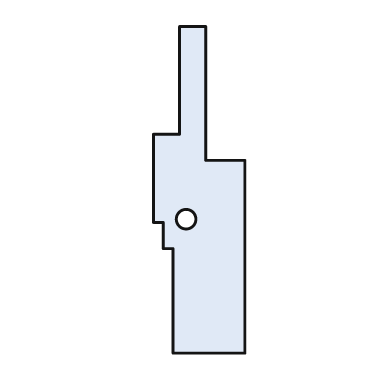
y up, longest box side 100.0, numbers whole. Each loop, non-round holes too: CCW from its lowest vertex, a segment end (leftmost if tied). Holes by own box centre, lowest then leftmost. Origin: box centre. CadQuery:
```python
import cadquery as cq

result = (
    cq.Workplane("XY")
    .moveTo(-8.0, -50.0)
    .lineTo(14.0, -50.0)
    .lineTo(14.0, 9.0)
    .lineTo(2.0, 9.0)
    .lineTo(2.0, 50.0)
    .lineTo(-6.0, 50.0)
    .lineTo(-6.0, 17.0)
    .lineTo(-14.0, 17.0)
    .lineTo(-14.0, -10.0)
    .lineTo(-11.0, -10.0)
    .lineTo(-11.0, -18.0)
    .lineTo(-8.0, -18.0)
    .close()
    .moveTo(-4.0, -9.0)
    .circle(3.0)
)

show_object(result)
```